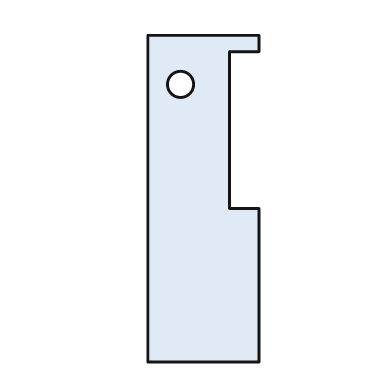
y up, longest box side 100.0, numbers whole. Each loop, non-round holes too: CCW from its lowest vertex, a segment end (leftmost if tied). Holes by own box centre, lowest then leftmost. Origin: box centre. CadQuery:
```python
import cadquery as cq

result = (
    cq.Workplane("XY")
    .moveTo(-17.0, -50.0)
    .lineTo(17.0, -50.0)
    .lineTo(17.0, -3.0)
    .lineTo(8.0, -3.0)
    .lineTo(8.0, 45.0)
    .lineTo(17.0, 45.0)
    .lineTo(17.0, 50.0)
    .lineTo(-17.0, 50.0)
    .close()
    .moveTo(-7.0, 35.0)
    .circle(4.0)
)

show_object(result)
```